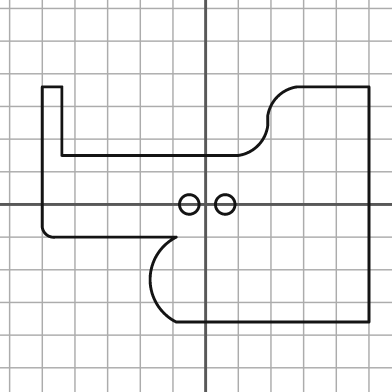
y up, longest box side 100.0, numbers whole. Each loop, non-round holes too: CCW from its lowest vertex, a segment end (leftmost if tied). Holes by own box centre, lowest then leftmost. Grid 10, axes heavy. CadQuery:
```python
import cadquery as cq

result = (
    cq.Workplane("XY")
    .moveTo(-9.0, -36.0)
    .lineTo(50.0, -36.0)
    .lineTo(50.0, 36.0)
    .lineTo(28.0, 36.0)
    .threePointArc((22.0, 33.0), (19.0, 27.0))
    .lineTo(19.0, 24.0)
    .threePointArc((16.0, 18.0), (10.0, 15.0))
    .lineTo(-44.0, 15.0)
    .lineTo(-44.0, 36.0)
    .lineTo(-50.0, 36.0)
    .lineTo(-50.0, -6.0)
    .threePointArc((-49.0, -9.0), (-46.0, -10.0))
    .lineTo(-9.0, -10.0)
    .threePointArc((-17.0, -23.0), (-9.0, -36.0))
    .close()
    .moveTo(-5.0, 0.0)
    .circle(3.0)
    .moveTo(6.0, 0.0)
    .circle(3.0)
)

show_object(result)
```